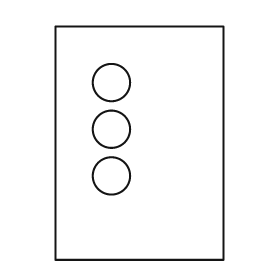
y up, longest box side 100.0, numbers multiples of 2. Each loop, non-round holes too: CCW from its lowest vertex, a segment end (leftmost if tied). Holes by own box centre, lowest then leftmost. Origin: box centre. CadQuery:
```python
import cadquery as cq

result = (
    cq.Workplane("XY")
    .moveTo(-36.0, -50.0)
    .lineTo(36.0, -50.0)
    .lineTo(36.0, 50.0)
    .lineTo(-36.0, 50.0)
    .close()
    .moveTo(-12.0, -14.0)
    .circle(8.0)
    .moveTo(-12.0, 6.0)
    .circle(8.0)
    .moveTo(-12.0, 26.0)
    .circle(8.0)
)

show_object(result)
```